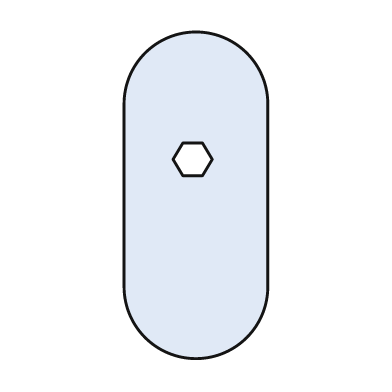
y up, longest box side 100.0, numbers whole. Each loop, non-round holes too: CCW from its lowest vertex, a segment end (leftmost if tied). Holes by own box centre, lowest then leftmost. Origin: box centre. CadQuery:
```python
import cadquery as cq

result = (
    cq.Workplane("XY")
    .moveTo(-22.0, -28.0)
    .threePointArc((0.0, -50.0), (22.0, -28.0))
    .lineTo(22.0, 28.0)
    .threePointArc((0.0, 50.0), (-22.0, 28.0))
    .close()
    .moveTo(-4.0, 6.0)
    .lineTo(2.0, 6.0)
    .lineTo(5.0, 11.0)
    .lineTo(2.0, 16.0)
    .lineTo(-4.0, 16.0)
    .lineTo(-7.0, 11.0)
    .close()
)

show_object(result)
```